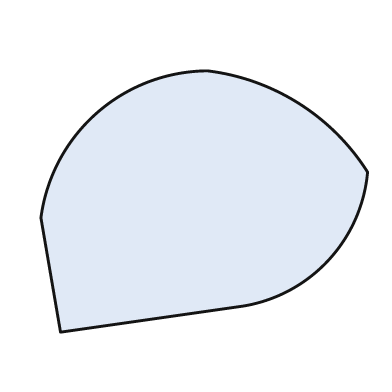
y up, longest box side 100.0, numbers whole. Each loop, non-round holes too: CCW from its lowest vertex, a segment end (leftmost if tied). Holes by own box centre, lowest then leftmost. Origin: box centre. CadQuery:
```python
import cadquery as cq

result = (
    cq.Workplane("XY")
    .moveTo(-44.0, -40.0)
    .lineTo(12.0, -32.0)
    .threePointArc((38.0, -18.0), (50.0, 9.0))
    .threePointArc((29.0, 30.0), (1.0, 40.0))
    .threePointArc((-33.0, 27.0), (-50.0, -5.0))
    .close()
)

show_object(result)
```